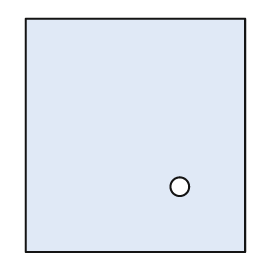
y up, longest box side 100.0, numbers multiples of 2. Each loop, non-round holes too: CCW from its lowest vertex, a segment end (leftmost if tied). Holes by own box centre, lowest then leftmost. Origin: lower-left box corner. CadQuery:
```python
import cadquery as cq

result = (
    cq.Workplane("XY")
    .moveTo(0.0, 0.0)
    .lineTo(94.0, 0.0)
    .lineTo(94.0, 100.0)
    .lineTo(0.0, 100.0)
    .close()
    .moveTo(66.0, 28.0)
    .circle(4.0)
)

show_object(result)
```